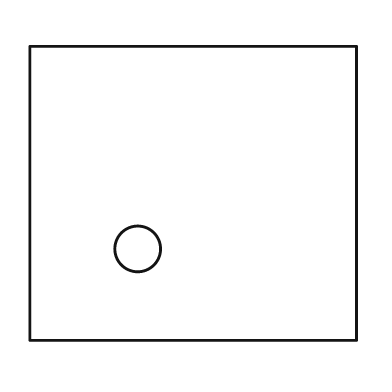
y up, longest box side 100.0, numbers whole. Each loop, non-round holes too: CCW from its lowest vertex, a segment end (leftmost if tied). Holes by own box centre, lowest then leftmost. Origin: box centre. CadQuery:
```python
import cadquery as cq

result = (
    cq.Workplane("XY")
    .moveTo(-50.0, -45.0)
    .lineTo(50.0, -45.0)
    .lineTo(50.0, 45.0)
    .lineTo(-50.0, 45.0)
    .close()
    .moveTo(-17.0, -17.0)
    .circle(7.0)
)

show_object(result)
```